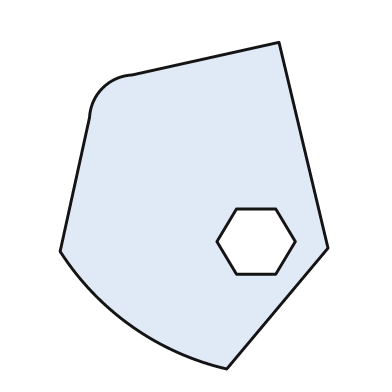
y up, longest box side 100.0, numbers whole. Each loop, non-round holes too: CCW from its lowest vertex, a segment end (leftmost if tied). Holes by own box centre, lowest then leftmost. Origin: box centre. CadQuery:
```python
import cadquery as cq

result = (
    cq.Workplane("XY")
    .moveTo(10.0, -50.0)
    .lineTo(41.0, -13.0)
    .lineTo(26.0, 50.0)
    .lineTo(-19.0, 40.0)
    .threePointArc((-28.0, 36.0), (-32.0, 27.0))
    .lineTo(-41.0, -14.0)
    .threePointArc((-19.0, -37.0), (10.0, -50.0))
    .close()
    .moveTo(13.0, -21.0)
    .lineTo(25.0, -21.0)
    .lineTo(31.0, -11.0)
    .lineTo(25.0, -1.0)
    .lineTo(13.0, -1.0)
    .lineTo(7.0, -11.0)
    .close()
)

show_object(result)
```